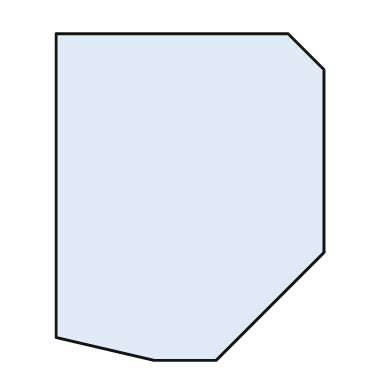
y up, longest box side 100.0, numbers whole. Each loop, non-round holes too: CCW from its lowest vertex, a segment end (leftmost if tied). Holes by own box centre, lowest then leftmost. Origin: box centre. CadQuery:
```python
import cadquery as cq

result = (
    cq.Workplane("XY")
    .moveTo(-11.0, -50.0)
    .lineTo(8.0, -50.0)
    .lineTo(41.0, -17.0)
    .lineTo(41.0, 39.0)
    .lineTo(30.0, 50.0)
    .lineTo(-41.0, 50.0)
    .lineTo(-41.0, -43.0)
    .close()
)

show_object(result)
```